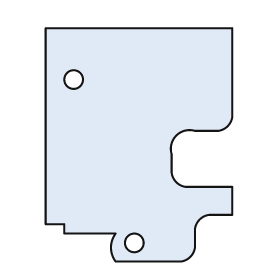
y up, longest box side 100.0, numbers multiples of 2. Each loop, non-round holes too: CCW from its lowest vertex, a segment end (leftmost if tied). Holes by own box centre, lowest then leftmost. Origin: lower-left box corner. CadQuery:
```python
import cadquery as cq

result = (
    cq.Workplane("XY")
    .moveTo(30.0, 0.0)
    .lineTo(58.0, 0.0)
    .threePointArc((62.0, 2.0), (64.0, 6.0))
    .lineTo(64.0, 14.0)
    .threePointArc((66.0, 18.0), (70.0, 20.0))
    .lineTo(80.0, 20.0)
    .lineTo(80.0, 32.0)
    .lineTo(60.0, 32.0)
    .threePointArc((56.0, 34.0), (54.0, 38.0))
    .lineTo(54.0, 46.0)
    .threePointArc((56.0, 54.0), (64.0, 56.0))
    .lineTo(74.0, 56.0)
    .threePointArc((78.0, 58.0), (80.0, 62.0))
    .lineTo(80.0, 100.0)
    .lineTo(0.0, 100.0)
    .lineTo(0.0, 16.0)
    .lineTo(8.0, 16.0)
    .lineTo(8.0, 12.0)
    .lineTo(30.0, 12.0)
    .threePointArc((28.0, 6.0), (30.0, 0.0))
    .close()
    .moveTo(38.0, 8.0)
    .circle(4.0)
    .moveTo(12.0, 78.0)
    .circle(4.0)
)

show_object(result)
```